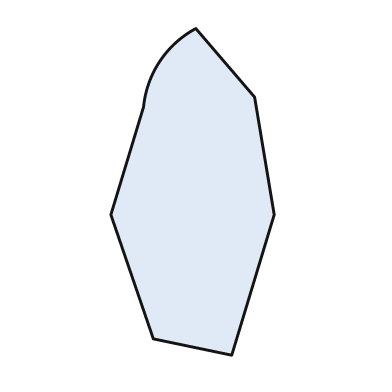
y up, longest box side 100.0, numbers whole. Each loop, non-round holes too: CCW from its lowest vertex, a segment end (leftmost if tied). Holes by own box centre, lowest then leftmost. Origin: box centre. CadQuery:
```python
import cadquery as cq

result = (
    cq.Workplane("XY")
    .moveTo(12.0, -50.0)
    .lineTo(25.0, -7.0)
    .lineTo(19.0, 29.0)
    .lineTo(1.0, 50.0)
    .threePointArc((-10.0, 40.0), (-15.0, 26.0))
    .lineTo(-25.0, -7.0)
    .lineTo(-12.0, -45.0)
    .close()
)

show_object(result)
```